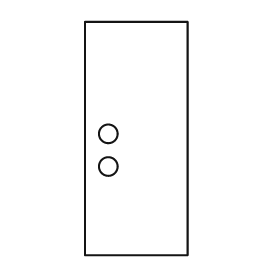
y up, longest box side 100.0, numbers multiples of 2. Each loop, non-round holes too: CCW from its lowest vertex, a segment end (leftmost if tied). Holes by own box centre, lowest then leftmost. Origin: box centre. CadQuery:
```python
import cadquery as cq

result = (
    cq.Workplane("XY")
    .moveTo(-22.0, -50.0)
    .lineTo(22.0, -50.0)
    .lineTo(22.0, 50.0)
    .lineTo(-22.0, 50.0)
    .close()
    .moveTo(-12.0, -12.0)
    .circle(4.0)
    .moveTo(-12.0, 2.0)
    .circle(4.0)
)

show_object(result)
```